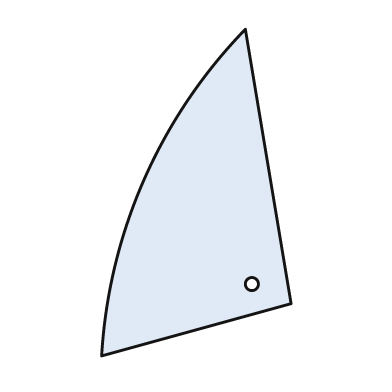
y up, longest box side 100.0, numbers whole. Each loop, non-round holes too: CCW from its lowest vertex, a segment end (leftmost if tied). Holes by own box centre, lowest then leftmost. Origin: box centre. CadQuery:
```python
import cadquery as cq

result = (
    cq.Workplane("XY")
    .moveTo(-29.0, -50.0)
    .lineTo(29.0, -34.0)
    .lineTo(15.0, 50.0)
    .threePointArc((-16.0, 4.0), (-29.0, -50.0))
    .close()
    .moveTo(17.0, -28.0)
    .circle(2.0)
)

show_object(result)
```